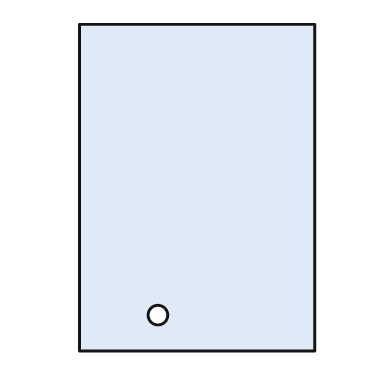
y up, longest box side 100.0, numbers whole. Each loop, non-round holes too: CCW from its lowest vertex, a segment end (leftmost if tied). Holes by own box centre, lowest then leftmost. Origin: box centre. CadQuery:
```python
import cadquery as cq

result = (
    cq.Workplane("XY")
    .moveTo(-36.0, -50.0)
    .lineTo(36.0, -50.0)
    .lineTo(36.0, 50.0)
    .lineTo(-36.0, 50.0)
    .close()
    .moveTo(-12.0, -39.0)
    .circle(3.0)
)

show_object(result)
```